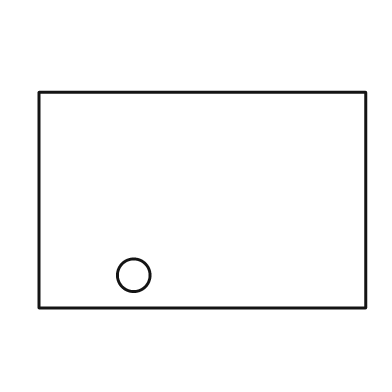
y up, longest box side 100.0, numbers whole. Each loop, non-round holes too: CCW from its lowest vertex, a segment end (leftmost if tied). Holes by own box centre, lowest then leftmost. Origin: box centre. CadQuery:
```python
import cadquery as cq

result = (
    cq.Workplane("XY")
    .moveTo(-50.0, -33.0)
    .lineTo(50.0, -33.0)
    .lineTo(50.0, 33.0)
    .lineTo(-50.0, 33.0)
    .close()
    .moveTo(-21.0, -23.0)
    .circle(5.0)
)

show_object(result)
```